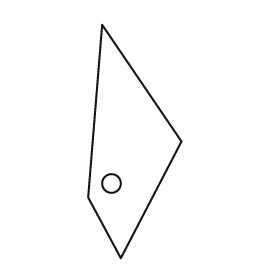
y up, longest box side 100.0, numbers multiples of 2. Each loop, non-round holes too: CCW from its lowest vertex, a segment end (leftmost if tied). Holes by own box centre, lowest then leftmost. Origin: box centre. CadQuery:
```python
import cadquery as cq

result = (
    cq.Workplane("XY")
    .moveTo(-6.0, -50.0)
    .lineTo(20.0, 0.0)
    .lineTo(-14.0, 50.0)
    .lineTo(-20.0, -24.0)
    .close()
    .moveTo(-10.0, -18.0)
    .circle(4.0)
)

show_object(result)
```